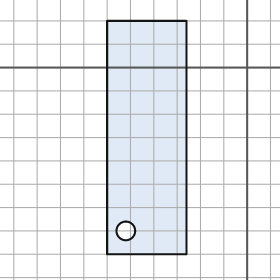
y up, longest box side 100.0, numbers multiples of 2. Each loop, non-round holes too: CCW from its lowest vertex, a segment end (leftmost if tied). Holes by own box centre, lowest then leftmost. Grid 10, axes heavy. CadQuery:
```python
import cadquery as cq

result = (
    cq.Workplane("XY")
    .moveTo(-60.0, -80.0)
    .lineTo(-26.0, -80.0)
    .lineTo(-26.0, 20.0)
    .lineTo(-60.0, 20.0)
    .close()
    .moveTo(-52.0, -70.0)
    .circle(4.0)
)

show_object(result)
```